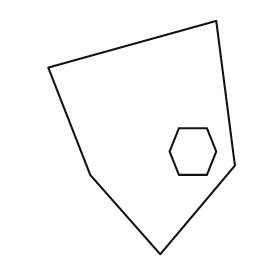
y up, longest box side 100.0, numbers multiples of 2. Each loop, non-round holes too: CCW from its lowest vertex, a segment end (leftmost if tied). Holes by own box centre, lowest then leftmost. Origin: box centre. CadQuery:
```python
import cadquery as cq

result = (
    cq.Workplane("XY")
    .moveTo(8.0, -50.0)
    .lineTo(40.0, -12.0)
    .lineTo(32.0, 50.0)
    .lineTo(-40.0, 30.0)
    .lineTo(-22.0, -16.0)
    .close()
    .moveTo(16.0, -16.0)
    .lineTo(28.0, -16.0)
    .lineTo(32.0, -6.0)
    .lineTo(28.0, 4.0)
    .lineTo(16.0, 4.0)
    .lineTo(12.0, -6.0)
    .close()
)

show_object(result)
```